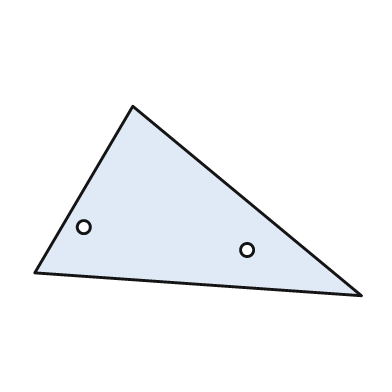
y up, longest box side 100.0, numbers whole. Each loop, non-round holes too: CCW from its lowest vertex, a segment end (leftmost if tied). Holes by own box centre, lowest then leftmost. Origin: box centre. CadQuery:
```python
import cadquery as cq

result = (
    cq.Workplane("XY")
    .moveTo(50.0, -29.0)
    .lineTo(-20.0, 29.0)
    .lineTo(-50.0, -22.0)
    .close()
    .moveTo(15.0, -15.0)
    .circle(2.0)
    .moveTo(-35.0, -8.0)
    .circle(2.0)
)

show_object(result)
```